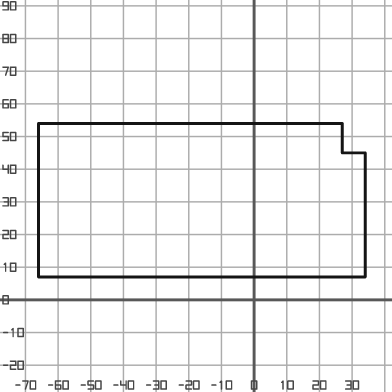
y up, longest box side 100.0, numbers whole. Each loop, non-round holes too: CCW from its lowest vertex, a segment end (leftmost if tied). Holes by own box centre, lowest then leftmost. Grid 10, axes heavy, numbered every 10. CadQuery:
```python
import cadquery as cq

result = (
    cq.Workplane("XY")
    .moveTo(-66.0, 7.0)
    .lineTo(34.0, 7.0)
    .lineTo(34.0, 45.0)
    .lineTo(27.0, 45.0)
    .lineTo(27.0, 54.0)
    .lineTo(-66.0, 54.0)
    .close()
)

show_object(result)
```